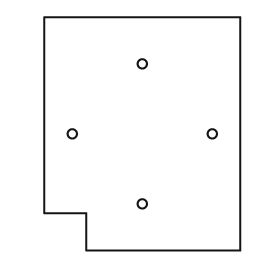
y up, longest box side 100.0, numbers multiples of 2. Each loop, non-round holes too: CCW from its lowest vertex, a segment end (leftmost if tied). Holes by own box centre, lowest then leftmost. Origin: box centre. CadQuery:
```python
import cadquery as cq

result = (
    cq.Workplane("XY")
    .moveTo(-24.0, -50.0)
    .lineTo(42.0, -50.0)
    .lineTo(42.0, 50.0)
    .lineTo(-42.0, 50.0)
    .lineTo(-42.0, -34.0)
    .lineTo(-24.0, -34.0)
    .close()
    .moveTo(0.0, -30.0)
    .circle(2.0)
    .moveTo(-30.0, 0.0)
    .circle(2.0)
    .moveTo(30.0, 0.0)
    .circle(2.0)
    .moveTo(0.0, 30.0)
    .circle(2.0)
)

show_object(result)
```